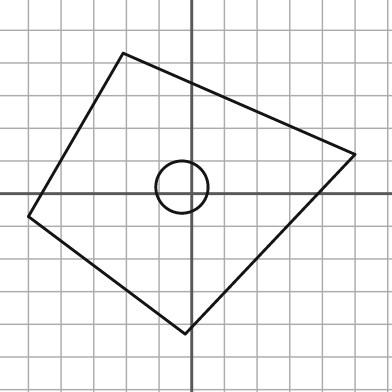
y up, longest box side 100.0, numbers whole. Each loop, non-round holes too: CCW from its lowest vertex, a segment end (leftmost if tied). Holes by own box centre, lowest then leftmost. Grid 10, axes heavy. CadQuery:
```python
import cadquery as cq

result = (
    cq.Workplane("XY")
    .moveTo(-2.0, -43.0)
    .lineTo(50.0, 12.0)
    .lineTo(-21.0, 43.0)
    .lineTo(-50.0, -7.0)
    .close()
    .moveTo(-3.0, 2.0)
    .circle(8.0)
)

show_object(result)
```